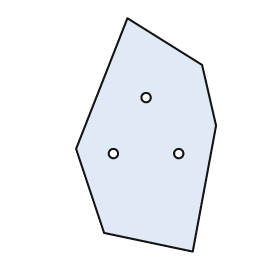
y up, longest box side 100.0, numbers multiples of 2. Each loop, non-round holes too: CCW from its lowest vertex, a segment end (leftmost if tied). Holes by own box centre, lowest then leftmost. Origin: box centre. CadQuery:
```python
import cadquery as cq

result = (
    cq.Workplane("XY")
    .moveTo(20.0, -50.0)
    .lineTo(30.0, 4.0)
    .lineTo(24.0, 30.0)
    .lineTo(-8.0, 50.0)
    .lineTo(-30.0, -6.0)
    .lineTo(-18.0, -42.0)
    .close()
    .moveTo(-14.0, -8.0)
    .circle(2.0)
    .moveTo(14.0, -8.0)
    .circle(2.0)
    .moveTo(0.0, 16.0)
    .circle(2.0)
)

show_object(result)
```